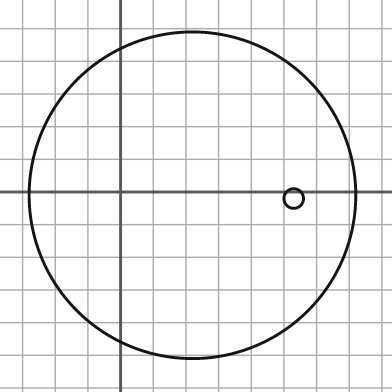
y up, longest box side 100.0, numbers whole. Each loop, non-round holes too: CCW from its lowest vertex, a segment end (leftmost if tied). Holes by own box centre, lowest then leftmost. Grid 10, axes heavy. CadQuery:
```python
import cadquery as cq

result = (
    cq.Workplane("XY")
    .moveTo(22.0, -1.0)
    .circle(50.0)
    .moveTo(53.0, -2.0)
    .circle(3.0)
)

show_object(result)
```